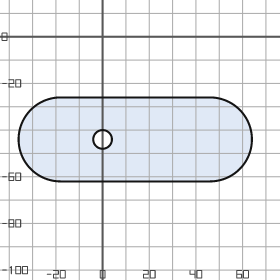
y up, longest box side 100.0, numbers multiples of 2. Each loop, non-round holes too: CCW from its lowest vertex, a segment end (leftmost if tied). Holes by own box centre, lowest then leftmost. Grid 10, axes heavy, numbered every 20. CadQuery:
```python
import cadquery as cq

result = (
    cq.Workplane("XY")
    .moveTo(-18.0, -62.0)
    .lineTo(46.0, -62.0)
    .threePointArc((64.0, -44.0), (46.0, -26.0))
    .lineTo(-18.0, -26.0)
    .threePointArc((-36.0, -44.0), (-18.0, -62.0))
    .close()
    .moveTo(0.0, -44.0)
    .circle(4.0)
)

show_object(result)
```